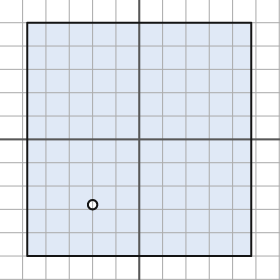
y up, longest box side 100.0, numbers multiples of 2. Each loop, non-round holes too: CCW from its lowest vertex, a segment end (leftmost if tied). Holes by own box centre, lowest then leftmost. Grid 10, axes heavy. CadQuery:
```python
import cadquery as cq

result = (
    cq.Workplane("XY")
    .moveTo(-48.0, -50.0)
    .lineTo(48.0, -50.0)
    .lineTo(48.0, 50.0)
    .lineTo(-48.0, 50.0)
    .close()
    .moveTo(-20.0, -28.0)
    .circle(2.0)
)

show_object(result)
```